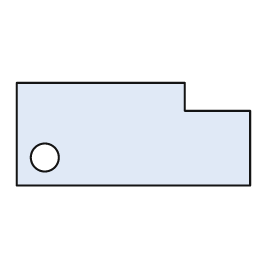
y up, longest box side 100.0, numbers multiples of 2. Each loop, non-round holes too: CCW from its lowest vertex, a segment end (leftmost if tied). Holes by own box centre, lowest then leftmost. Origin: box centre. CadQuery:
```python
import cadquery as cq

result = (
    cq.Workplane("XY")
    .moveTo(-50.0, -22.0)
    .lineTo(50.0, -22.0)
    .lineTo(50.0, 10.0)
    .lineTo(22.0, 10.0)
    .lineTo(22.0, 22.0)
    .lineTo(-50.0, 22.0)
    .close()
    .moveTo(-38.0, -10.0)
    .circle(6.0)
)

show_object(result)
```